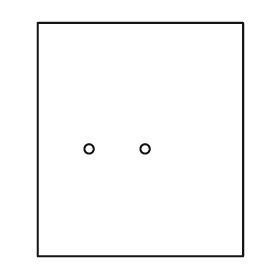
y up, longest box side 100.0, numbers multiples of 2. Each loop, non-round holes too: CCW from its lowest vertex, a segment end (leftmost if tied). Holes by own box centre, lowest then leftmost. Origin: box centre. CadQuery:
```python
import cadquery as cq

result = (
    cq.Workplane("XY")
    .moveTo(-44.0, -50.0)
    .lineTo(44.0, -50.0)
    .lineTo(44.0, 50.0)
    .lineTo(-44.0, 50.0)
    .close()
    .moveTo(-22.0, -4.0)
    .circle(2.0)
    .moveTo(2.0, -4.0)
    .circle(2.0)
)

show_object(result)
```